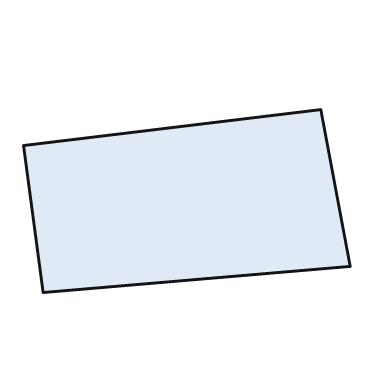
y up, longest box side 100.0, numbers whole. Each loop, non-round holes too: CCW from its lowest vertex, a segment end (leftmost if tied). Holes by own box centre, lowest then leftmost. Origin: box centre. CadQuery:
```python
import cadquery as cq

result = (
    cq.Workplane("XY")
    .moveTo(-44.0, -28.0)
    .lineTo(50.0, -20.0)
    .lineTo(41.0, 28.0)
    .lineTo(-50.0, 17.0)
    .close()
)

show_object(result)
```